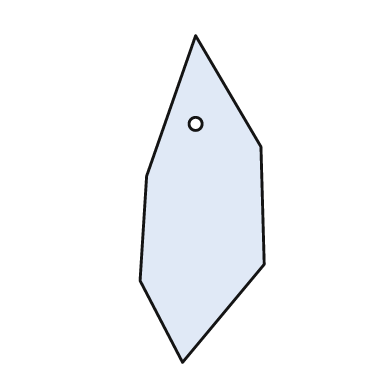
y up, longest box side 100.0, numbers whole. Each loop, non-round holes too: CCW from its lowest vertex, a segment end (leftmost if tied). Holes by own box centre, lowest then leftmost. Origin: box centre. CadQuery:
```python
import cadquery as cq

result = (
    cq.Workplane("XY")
    .moveTo(-6.0, -50.0)
    .lineTo(19.0, -20.0)
    .lineTo(18.0, 16.0)
    .lineTo(-2.0, 50.0)
    .lineTo(-17.0, 7.0)
    .lineTo(-19.0, -25.0)
    .close()
    .moveTo(-2.0, 23.0)
    .circle(2.0)
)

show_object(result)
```